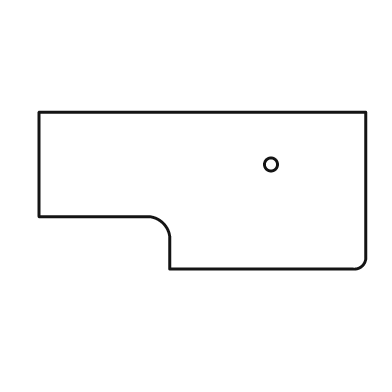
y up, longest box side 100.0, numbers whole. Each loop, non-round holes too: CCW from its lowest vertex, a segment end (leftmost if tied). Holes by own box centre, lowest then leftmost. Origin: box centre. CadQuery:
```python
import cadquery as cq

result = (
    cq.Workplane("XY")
    .moveTo(-10.0, -24.0)
    .lineTo(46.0, -24.0)
    .threePointArc((49.0, -23.0), (50.0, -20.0))
    .lineTo(50.0, 24.0)
    .lineTo(-50.0, 24.0)
    .lineTo(-50.0, -8.0)
    .lineTo(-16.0, -8.0)
    .threePointArc((-12.0, -10.0), (-10.0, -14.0))
    .close()
    .moveTo(21.0, 8.0)
    .circle(2.0)
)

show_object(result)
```